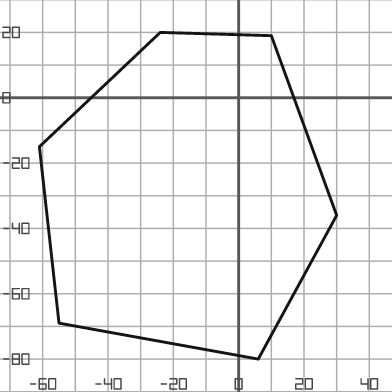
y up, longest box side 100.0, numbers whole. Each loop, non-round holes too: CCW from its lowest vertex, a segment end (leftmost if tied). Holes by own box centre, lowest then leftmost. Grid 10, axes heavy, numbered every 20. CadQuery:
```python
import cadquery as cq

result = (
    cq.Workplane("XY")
    .moveTo(6.0, -80.0)
    .lineTo(30.0, -36.0)
    .lineTo(10.0, 19.0)
    .lineTo(-24.0, 20.0)
    .lineTo(-61.0, -15.0)
    .lineTo(-55.0, -69.0)
    .close()
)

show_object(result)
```